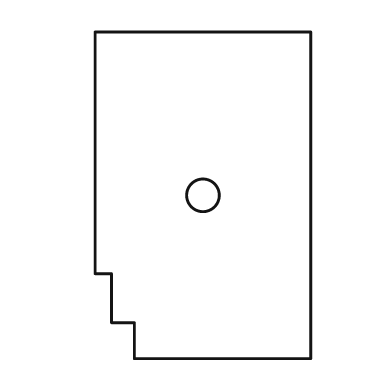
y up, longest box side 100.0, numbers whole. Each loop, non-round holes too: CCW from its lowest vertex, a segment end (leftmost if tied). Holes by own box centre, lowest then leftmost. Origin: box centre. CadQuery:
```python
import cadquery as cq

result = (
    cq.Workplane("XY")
    .moveTo(-21.0, -50.0)
    .lineTo(33.0, -50.0)
    .lineTo(33.0, 50.0)
    .lineTo(-33.0, 50.0)
    .lineTo(-33.0, -24.0)
    .lineTo(-28.0, -24.0)
    .lineTo(-28.0, -39.0)
    .lineTo(-21.0, -39.0)
    .close()
    .moveTo(0.0, 0.0)
    .circle(5.0)
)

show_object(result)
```